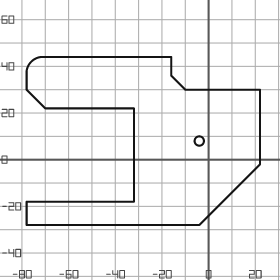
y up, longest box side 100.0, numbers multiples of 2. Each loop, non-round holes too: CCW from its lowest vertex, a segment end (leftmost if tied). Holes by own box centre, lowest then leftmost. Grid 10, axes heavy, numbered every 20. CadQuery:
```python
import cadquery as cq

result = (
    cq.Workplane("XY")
    .moveTo(-78.0, -28.0)
    .lineTo(-4.0, -28.0)
    .lineTo(22.0, -2.0)
    .lineTo(22.0, 30.0)
    .lineTo(-10.0, 30.0)
    .lineTo(-16.0, 36.0)
    .lineTo(-16.0, 44.0)
    .lineTo(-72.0, 44.0)
    .threePointArc((-76.0, 42.0), (-78.0, 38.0))
    .lineTo(-78.0, 30.0)
    .lineTo(-70.0, 22.0)
    .lineTo(-32.0, 22.0)
    .lineTo(-32.0, -18.0)
    .lineTo(-78.0, -18.0)
    .close()
    .moveTo(-4.0, 8.0)
    .circle(2.0)
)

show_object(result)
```